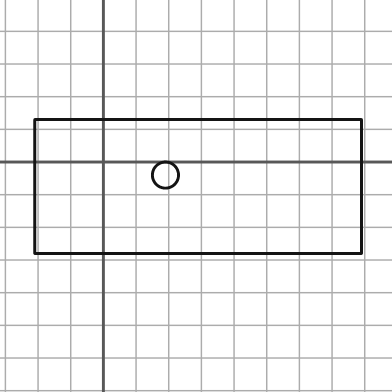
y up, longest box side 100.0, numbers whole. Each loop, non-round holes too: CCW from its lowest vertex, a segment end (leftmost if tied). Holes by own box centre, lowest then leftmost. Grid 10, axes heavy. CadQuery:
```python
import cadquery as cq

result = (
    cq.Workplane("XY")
    .moveTo(-21.0, -28.0)
    .lineTo(79.0, -28.0)
    .lineTo(79.0, 13.0)
    .lineTo(-21.0, 13.0)
    .close()
    .moveTo(19.0, -4.0)
    .circle(4.0)
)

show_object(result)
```